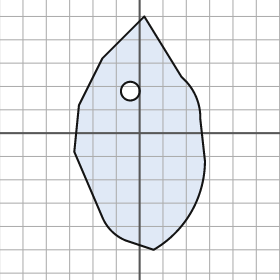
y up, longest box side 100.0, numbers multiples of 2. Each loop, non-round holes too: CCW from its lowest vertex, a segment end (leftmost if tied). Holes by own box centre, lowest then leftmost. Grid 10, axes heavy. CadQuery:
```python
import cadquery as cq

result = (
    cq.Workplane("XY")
    .moveTo(6.0, -50.0)
    .threePointArc((22.0, -34.0), (28.0, -12.0))
    .lineTo(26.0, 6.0)
    .threePointArc((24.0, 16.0), (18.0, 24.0))
    .lineTo(2.0, 50.0)
    .lineTo(-16.0, 32.0)
    .lineTo(-26.0, 12.0)
    .lineTo(-28.0, -8.0)
    .lineTo(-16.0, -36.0)
    .threePointArc((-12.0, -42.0), (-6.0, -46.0))
    .close()
    .moveTo(-4.0, 18.0)
    .circle(4.0)
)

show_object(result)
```